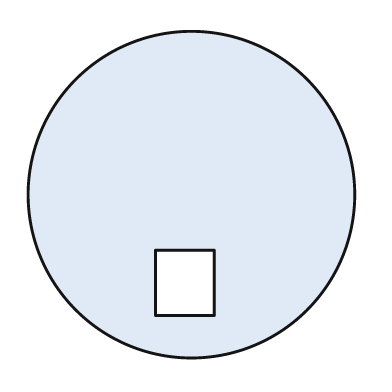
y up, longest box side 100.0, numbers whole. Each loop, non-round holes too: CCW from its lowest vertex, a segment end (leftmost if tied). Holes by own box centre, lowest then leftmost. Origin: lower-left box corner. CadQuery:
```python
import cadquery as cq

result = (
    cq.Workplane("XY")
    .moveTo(50.0, 50.0)
    .circle(50.0)
    .moveTo(39.0, 13.0)
    .lineTo(57.0, 13.0)
    .lineTo(57.0, 33.0)
    .lineTo(39.0, 33.0)
    .close()
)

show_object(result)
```